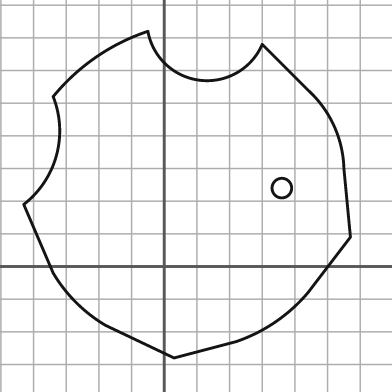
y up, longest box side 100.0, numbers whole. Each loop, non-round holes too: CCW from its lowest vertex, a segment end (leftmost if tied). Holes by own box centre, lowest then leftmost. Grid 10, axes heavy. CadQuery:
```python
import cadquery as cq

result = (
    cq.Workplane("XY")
    .moveTo(3.0, -28.0)
    .lineTo(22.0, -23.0)
    .threePointArc((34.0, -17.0), (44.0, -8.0))
    .lineTo(57.0, 9.0)
    .lineTo(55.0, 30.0)
    .threePointArc((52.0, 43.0), (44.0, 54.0))
    .lineTo(30.0, 68.0)
    .threePointArc((11.0, 57.0), (-5.0, 72.0))
    .threePointArc((-21.0, 64.0), (-34.0, 52.0))
    .threePointArc((-33.0, 34.0), (-43.0, 19.0))
    .lineTo(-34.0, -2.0)
    .threePointArc((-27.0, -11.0), (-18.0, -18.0))
    .close()
    .moveTo(36.0, 24.0)
    .circle(3.0)
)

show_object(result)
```